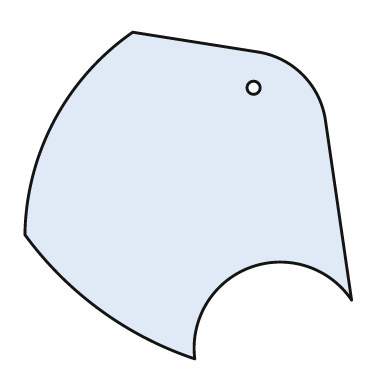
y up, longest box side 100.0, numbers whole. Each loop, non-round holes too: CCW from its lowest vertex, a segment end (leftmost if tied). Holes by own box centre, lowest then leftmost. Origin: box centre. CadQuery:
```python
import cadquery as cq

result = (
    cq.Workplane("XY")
    .moveTo(2.0, -50.0)
    .threePointArc((19.0, -22.0), (50.0, -32.0))
    .lineTo(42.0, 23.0)
    .threePointArc((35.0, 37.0), (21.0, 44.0))
    .lineTo(-17.0, 50.0)
    .threePointArc((-41.0, 23.0), (-50.0, -12.0))
    .threePointArc((-27.0, -35.0), (2.0, -50.0))
    .close()
    .moveTo(20.0, 33.0)
    .circle(2.0)
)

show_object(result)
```